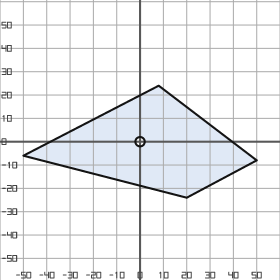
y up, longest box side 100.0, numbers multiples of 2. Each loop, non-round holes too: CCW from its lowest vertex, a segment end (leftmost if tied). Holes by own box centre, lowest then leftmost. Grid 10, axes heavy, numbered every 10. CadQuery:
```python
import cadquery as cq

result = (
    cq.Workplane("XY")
    .moveTo(20.0, -24.0)
    .lineTo(50.0, -8.0)
    .lineTo(8.0, 24.0)
    .lineTo(-50.0, -6.0)
    .close()
    .moveTo(0.0, 0.0)
    .circle(2.0)
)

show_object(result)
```